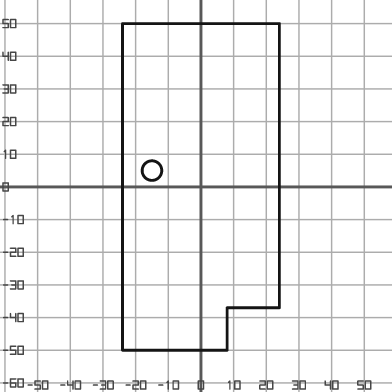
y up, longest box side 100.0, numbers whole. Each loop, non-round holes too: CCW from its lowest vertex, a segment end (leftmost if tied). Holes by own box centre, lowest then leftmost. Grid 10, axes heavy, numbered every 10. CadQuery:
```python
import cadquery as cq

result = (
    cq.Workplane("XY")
    .moveTo(-24.0, -50.0)
    .lineTo(8.0, -50.0)
    .lineTo(8.0, -37.0)
    .lineTo(24.0, -37.0)
    .lineTo(24.0, 50.0)
    .lineTo(-24.0, 50.0)
    .close()
    .moveTo(-15.0, 5.0)
    .circle(3.0)
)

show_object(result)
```